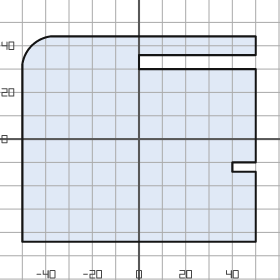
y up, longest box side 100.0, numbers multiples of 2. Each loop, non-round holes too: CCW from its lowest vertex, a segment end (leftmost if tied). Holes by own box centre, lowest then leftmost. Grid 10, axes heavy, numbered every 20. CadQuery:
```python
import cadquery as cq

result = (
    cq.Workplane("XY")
    .moveTo(-50.0, -44.0)
    .lineTo(50.0, -44.0)
    .lineTo(50.0, -14.0)
    .lineTo(40.0, -14.0)
    .lineTo(40.0, -10.0)
    .lineTo(50.0, -10.0)
    .lineTo(50.0, 30.0)
    .lineTo(0.0, 30.0)
    .lineTo(0.0, 36.0)
    .lineTo(50.0, 36.0)
    .lineTo(50.0, 44.0)
    .lineTo(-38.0, 44.0)
    .threePointArc((-46.0, 40.0), (-50.0, 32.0))
    .close()
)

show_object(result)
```